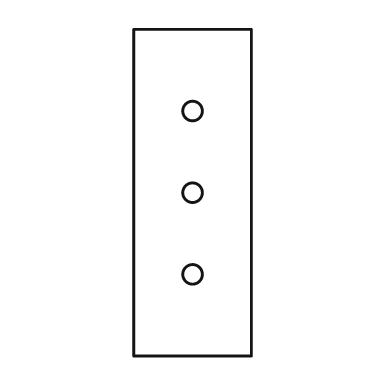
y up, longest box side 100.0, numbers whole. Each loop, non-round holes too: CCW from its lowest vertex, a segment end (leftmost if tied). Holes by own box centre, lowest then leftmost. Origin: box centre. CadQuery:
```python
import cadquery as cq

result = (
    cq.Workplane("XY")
    .moveTo(-18.0, -50.0)
    .lineTo(18.0, -50.0)
    .lineTo(18.0, 50.0)
    .lineTo(-18.0, 50.0)
    .close()
    .moveTo(0.0, -25.0)
    .circle(3.0)
    .moveTo(0.0, 0.0)
    .circle(3.0)
    .moveTo(0.0, 25.0)
    .circle(3.0)
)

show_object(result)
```